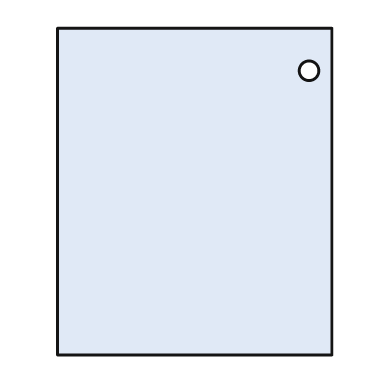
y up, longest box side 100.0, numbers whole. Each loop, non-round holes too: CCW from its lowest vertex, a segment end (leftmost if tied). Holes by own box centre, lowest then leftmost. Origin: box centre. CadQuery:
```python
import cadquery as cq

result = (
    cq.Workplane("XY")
    .moveTo(-42.0, -50.0)
    .lineTo(42.0, -50.0)
    .lineTo(42.0, 50.0)
    .lineTo(-42.0, 50.0)
    .close()
    .moveTo(35.0, 37.0)
    .circle(3.0)
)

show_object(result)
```